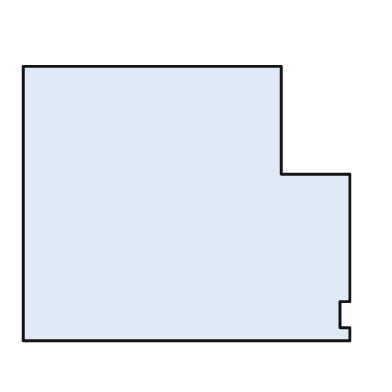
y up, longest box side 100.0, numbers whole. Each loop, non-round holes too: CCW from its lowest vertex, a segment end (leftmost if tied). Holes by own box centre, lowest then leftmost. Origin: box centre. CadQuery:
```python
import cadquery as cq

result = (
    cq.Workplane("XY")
    .moveTo(-50.0, -42.0)
    .lineTo(50.0, -42.0)
    .lineTo(50.0, -38.0)
    .lineTo(47.0, -38.0)
    .lineTo(47.0, -30.0)
    .lineTo(50.0, -30.0)
    .lineTo(50.0, 9.0)
    .lineTo(29.0, 9.0)
    .lineTo(29.0, 42.0)
    .lineTo(-50.0, 42.0)
    .close()
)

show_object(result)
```